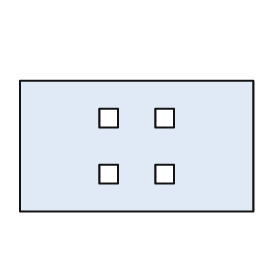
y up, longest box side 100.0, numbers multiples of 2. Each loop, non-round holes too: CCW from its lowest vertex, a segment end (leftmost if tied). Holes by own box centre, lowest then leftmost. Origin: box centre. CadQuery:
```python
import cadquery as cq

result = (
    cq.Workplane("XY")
    .moveTo(-50.0, -28.0)
    .lineTo(50.0, -28.0)
    .lineTo(50.0, 28.0)
    .lineTo(-50.0, 28.0)
    .close()
    .moveTo(-16.0, -16.0)
    .lineTo(-8.0, -16.0)
    .lineTo(-8.0, -8.0)
    .lineTo(-16.0, -8.0)
    .close()
    .moveTo(8.0, -16.0)
    .lineTo(16.0, -16.0)
    .lineTo(16.0, -8.0)
    .lineTo(8.0, -8.0)
    .close()
    .moveTo(-16.0, 8.0)
    .lineTo(-8.0, 8.0)
    .lineTo(-8.0, 16.0)
    .lineTo(-16.0, 16.0)
    .close()
    .moveTo(8.0, 8.0)
    .lineTo(16.0, 8.0)
    .lineTo(16.0, 16.0)
    .lineTo(8.0, 16.0)
    .close()
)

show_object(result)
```